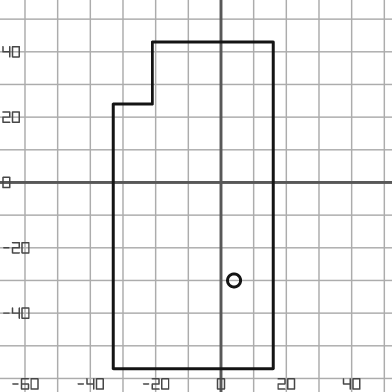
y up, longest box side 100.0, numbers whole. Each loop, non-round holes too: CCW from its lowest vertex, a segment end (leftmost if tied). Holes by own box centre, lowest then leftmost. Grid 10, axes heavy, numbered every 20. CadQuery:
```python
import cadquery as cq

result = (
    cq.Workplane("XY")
    .moveTo(-33.0, -57.0)
    .lineTo(16.0, -57.0)
    .lineTo(16.0, 43.0)
    .lineTo(-21.0, 43.0)
    .lineTo(-21.0, 24.0)
    .lineTo(-33.0, 24.0)
    .close()
    .moveTo(4.0, -30.0)
    .circle(2.0)
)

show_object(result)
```